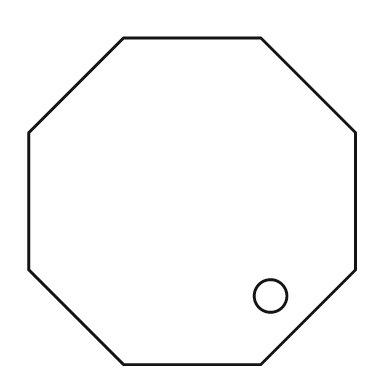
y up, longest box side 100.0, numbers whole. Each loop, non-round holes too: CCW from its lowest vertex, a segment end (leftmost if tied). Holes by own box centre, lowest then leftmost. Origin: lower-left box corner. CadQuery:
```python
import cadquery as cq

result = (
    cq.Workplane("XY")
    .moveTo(29.0, 0.0)
    .lineTo(71.0, 0.0)
    .lineTo(100.0, 29.0)
    .lineTo(100.0, 71.0)
    .lineTo(71.0, 100.0)
    .lineTo(29.0, 100.0)
    .lineTo(0.0, 71.0)
    .lineTo(0.0, 29.0)
    .close()
    .moveTo(74.0, 21.0)
    .circle(5.0)
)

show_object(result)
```